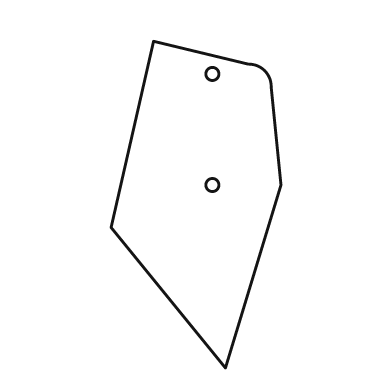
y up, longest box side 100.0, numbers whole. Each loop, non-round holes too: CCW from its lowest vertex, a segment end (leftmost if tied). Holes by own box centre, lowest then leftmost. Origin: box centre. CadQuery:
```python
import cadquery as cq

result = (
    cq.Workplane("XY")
    .moveTo(9.0, -50.0)
    .lineTo(26.0, 6.0)
    .lineTo(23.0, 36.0)
    .threePointArc((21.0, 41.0), (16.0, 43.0))
    .lineTo(-13.0, 50.0)
    .lineTo(-26.0, -7.0)
    .close()
    .moveTo(5.0, 6.0)
    .circle(2.0)
    .moveTo(5.0, 40.0)
    .circle(2.0)
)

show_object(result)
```